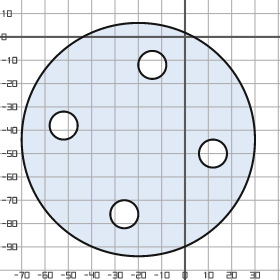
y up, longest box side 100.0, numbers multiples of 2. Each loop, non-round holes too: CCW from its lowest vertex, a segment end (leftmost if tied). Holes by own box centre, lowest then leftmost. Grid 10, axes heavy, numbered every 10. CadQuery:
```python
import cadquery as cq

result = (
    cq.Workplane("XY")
    .moveTo(-20.0, -44.0)
    .circle(50.0)
    .moveTo(-26.0, -76.0)
    .circle(6.0)
    .moveTo(12.0, -50.0)
    .circle(6.0)
    .moveTo(-52.0, -38.0)
    .circle(6.0)
    .moveTo(-14.0, -12.0)
    .circle(6.0)
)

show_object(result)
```